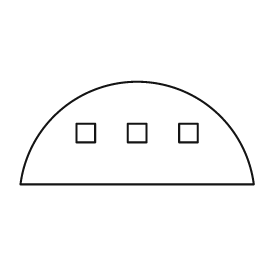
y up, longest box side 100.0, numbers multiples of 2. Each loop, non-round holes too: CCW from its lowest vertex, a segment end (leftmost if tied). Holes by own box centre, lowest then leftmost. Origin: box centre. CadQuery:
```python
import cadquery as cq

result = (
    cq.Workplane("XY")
    .moveTo(-50.0, -22.0)
    .lineTo(50.0, -22.0)
    .threePointArc((0.0, 22.0), (-50.0, -22.0))
    .close()
    .moveTo(-26.0, -4.0)
    .lineTo(-18.0, -4.0)
    .lineTo(-18.0, 4.0)
    .lineTo(-26.0, 4.0)
    .close()
    .moveTo(-4.0, -4.0)
    .lineTo(4.0, -4.0)
    .lineTo(4.0, 4.0)
    .lineTo(-4.0, 4.0)
    .close()
    .moveTo(18.0, -4.0)
    .lineTo(26.0, -4.0)
    .lineTo(26.0, 4.0)
    .lineTo(18.0, 4.0)
    .close()
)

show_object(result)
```